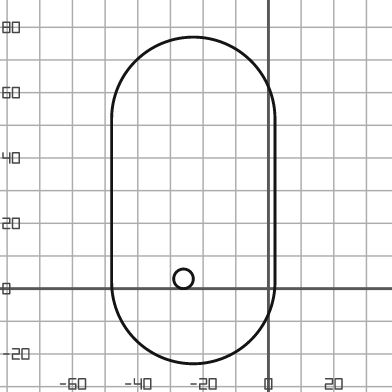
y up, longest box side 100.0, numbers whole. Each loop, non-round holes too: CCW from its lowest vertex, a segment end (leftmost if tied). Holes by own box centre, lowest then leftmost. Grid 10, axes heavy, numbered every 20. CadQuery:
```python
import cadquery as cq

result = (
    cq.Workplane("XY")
    .moveTo(-48.0, 2.0)
    .threePointArc((-23.0, -23.0), (2.0, 2.0))
    .lineTo(2.0, 52.0)
    .threePointArc((-23.0, 77.0), (-48.0, 52.0))
    .close()
    .moveTo(-26.0, 3.0)
    .circle(3.0)
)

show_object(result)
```